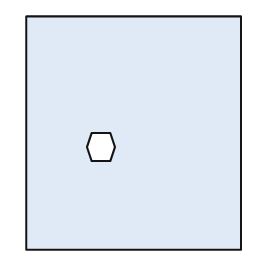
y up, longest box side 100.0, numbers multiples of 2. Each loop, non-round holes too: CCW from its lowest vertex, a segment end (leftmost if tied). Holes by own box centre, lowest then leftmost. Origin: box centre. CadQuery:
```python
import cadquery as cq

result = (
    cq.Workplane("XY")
    .moveTo(-46.0, -50.0)
    .lineTo(46.0, -50.0)
    .lineTo(46.0, 50.0)
    .lineTo(-46.0, 50.0)
    .close()
    .moveTo(-18.0, -12.0)
    .lineTo(-10.0, -12.0)
    .lineTo(-8.0, -6.0)
    .lineTo(-10.0, 0.0)
    .lineTo(-18.0, 0.0)
    .lineTo(-20.0, -6.0)
    .close()
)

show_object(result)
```